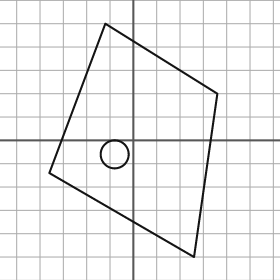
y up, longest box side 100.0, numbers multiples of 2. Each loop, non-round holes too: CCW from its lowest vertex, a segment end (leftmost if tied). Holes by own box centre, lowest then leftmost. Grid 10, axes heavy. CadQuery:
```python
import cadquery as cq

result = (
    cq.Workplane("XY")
    .moveTo(26.0, -50.0)
    .lineTo(36.0, 20.0)
    .lineTo(-12.0, 50.0)
    .lineTo(-36.0, -14.0)
    .close()
    .moveTo(-8.0, -6.0)
    .circle(6.0)
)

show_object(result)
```